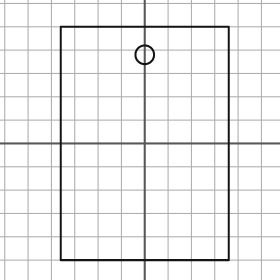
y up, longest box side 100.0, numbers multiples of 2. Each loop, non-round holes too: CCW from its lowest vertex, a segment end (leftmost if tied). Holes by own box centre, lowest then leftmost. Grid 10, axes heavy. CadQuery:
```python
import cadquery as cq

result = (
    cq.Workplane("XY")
    .moveTo(-36.0, -50.0)
    .lineTo(36.0, -50.0)
    .lineTo(36.0, 50.0)
    .lineTo(-36.0, 50.0)
    .close()
    .moveTo(0.0, 38.0)
    .circle(4.0)
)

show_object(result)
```